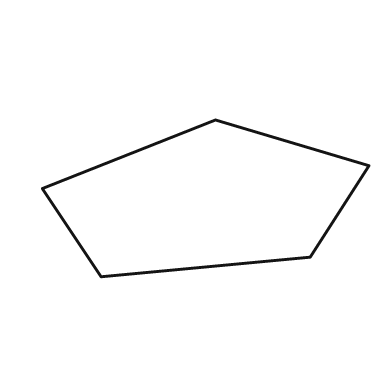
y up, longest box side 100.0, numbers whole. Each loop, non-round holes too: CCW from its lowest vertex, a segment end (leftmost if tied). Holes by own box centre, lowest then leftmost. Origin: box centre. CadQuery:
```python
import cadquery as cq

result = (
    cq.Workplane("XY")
    .moveTo(-32.0, -24.0)
    .lineTo(32.0, -18.0)
    .lineTo(50.0, 10.0)
    .lineTo(3.0, 24.0)
    .lineTo(-50.0, 3.0)
    .close()
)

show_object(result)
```